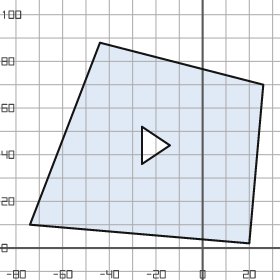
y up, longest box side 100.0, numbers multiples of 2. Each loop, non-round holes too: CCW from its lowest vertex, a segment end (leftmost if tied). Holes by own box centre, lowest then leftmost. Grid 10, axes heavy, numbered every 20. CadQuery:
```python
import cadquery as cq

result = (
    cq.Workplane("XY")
    .moveTo(20.0, 2.0)
    .lineTo(26.0, 70.0)
    .lineTo(-44.0, 88.0)
    .lineTo(-74.0, 10.0)
    .close()
    .moveTo(-26.0, 36.0)
    .lineTo(-14.0, 44.0)
    .lineTo(-26.0, 52.0)
    .close()
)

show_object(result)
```